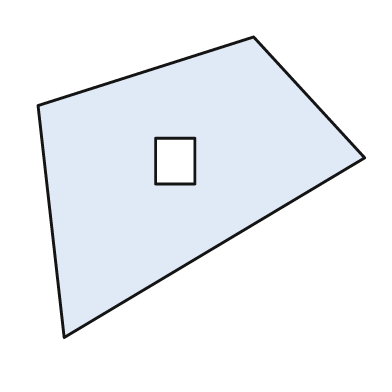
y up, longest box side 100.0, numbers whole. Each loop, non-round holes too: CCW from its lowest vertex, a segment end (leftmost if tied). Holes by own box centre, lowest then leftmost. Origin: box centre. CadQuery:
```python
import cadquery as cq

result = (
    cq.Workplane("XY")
    .moveTo(-42.0, -46.0)
    .lineTo(50.0, 9.0)
    .lineTo(16.0, 46.0)
    .lineTo(-50.0, 25.0)
    .close()
    .moveTo(-14.0, 1.0)
    .lineTo(-2.0, 1.0)
    .lineTo(-2.0, 15.0)
    .lineTo(-14.0, 15.0)
    .close()
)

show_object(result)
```